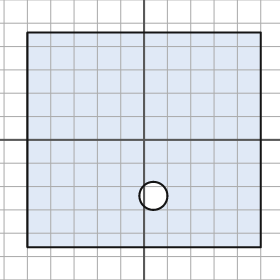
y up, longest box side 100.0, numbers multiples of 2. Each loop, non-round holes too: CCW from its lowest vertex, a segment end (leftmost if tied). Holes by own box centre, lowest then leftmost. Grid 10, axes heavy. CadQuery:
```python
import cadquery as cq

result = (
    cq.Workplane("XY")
    .moveTo(-50.0, -46.0)
    .lineTo(50.0, -46.0)
    .lineTo(50.0, 46.0)
    .lineTo(-50.0, 46.0)
    .close()
    .moveTo(4.0, -24.0)
    .circle(6.0)
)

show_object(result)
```